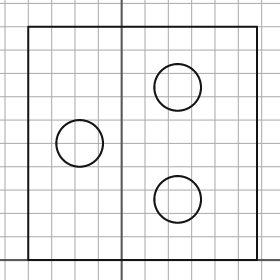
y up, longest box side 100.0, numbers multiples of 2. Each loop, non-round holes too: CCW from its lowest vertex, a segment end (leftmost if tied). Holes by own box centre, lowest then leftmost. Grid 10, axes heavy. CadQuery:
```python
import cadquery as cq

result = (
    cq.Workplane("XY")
    .moveTo(-40.0, 0.0)
    .lineTo(58.0, 0.0)
    .lineTo(58.0, 100.0)
    .lineTo(-40.0, 100.0)
    .close()
    .moveTo(24.0, 26.0)
    .circle(10.0)
    .moveTo(-18.0, 50.0)
    .circle(10.0)
    .moveTo(24.0, 74.0)
    .circle(10.0)
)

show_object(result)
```